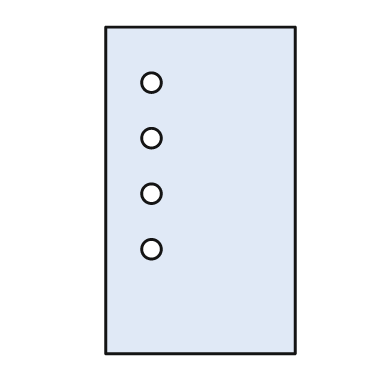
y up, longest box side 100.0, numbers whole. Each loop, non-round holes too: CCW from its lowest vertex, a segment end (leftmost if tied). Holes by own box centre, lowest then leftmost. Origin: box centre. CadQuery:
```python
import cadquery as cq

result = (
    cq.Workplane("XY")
    .moveTo(-29.0, -50.0)
    .lineTo(29.0, -50.0)
    .lineTo(29.0, 50.0)
    .lineTo(-29.0, 50.0)
    .close()
    .moveTo(-15.0, -18.0)
    .circle(3.0)
    .moveTo(-15.0, -1.0)
    .circle(3.0)
    .moveTo(-15.0, 16.0)
    .circle(3.0)
    .moveTo(-15.0, 33.0)
    .circle(3.0)
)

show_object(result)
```